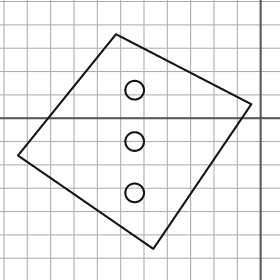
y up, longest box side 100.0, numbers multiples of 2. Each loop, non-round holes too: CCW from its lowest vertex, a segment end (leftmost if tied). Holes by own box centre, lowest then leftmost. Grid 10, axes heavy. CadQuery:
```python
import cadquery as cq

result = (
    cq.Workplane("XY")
    .moveTo(-46.0, -56.0)
    .lineTo(-4.0, 6.0)
    .lineTo(-62.0, 36.0)
    .lineTo(-104.0, -16.0)
    .close()
    .moveTo(-54.0, -32.0)
    .circle(4.0)
    .moveTo(-54.0, -10.0)
    .circle(4.0)
    .moveTo(-54.0, 12.0)
    .circle(4.0)
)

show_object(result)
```